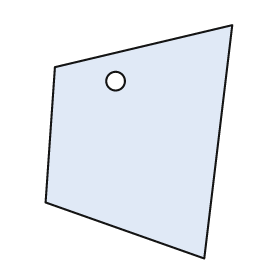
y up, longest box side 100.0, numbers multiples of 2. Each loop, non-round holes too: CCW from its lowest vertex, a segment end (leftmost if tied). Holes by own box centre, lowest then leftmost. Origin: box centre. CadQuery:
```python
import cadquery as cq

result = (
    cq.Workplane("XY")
    .moveTo(28.0, -50.0)
    .lineTo(40.0, 50.0)
    .lineTo(-36.0, 32.0)
    .lineTo(-40.0, -26.0)
    .close()
    .moveTo(-10.0, 26.0)
    .circle(4.0)
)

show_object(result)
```